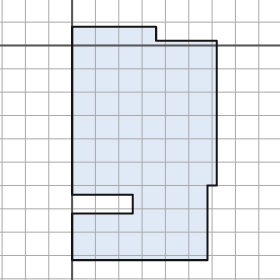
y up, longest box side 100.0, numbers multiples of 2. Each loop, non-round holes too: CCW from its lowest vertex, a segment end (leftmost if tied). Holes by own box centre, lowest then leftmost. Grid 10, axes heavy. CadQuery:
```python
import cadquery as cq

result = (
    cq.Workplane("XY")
    .moveTo(0.0, -92.0)
    .lineTo(58.0, -92.0)
    .lineTo(58.0, -60.0)
    .lineTo(62.0, -60.0)
    .lineTo(62.0, 2.0)
    .lineTo(36.0, 2.0)
    .lineTo(36.0, 8.0)
    .lineTo(0.0, 8.0)
    .lineTo(0.0, -64.0)
    .lineTo(26.0, -64.0)
    .lineTo(26.0, -72.0)
    .lineTo(0.0, -72.0)
    .close()
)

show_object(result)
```